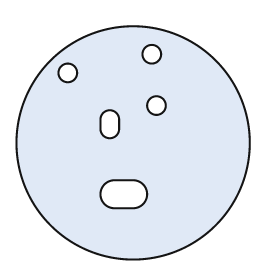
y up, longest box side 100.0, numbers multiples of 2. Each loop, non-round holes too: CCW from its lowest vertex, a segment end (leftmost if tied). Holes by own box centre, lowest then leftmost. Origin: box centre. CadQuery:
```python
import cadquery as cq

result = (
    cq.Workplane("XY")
    .moveTo(0.0, 0.0)
    .circle(50.0)
    .moveTo(-8.0, -28.0)
    .lineTo(0.0, -28.0)
    .threePointArc((6.0, -22.0), (0.0, -16.0))
    .lineTo(-8.0, -16.0)
    .threePointArc((-14.0, -22.0), (-8.0, -28.0))
    .close()
    .moveTo(-14.0, 6.0)
    .threePointArc((-10.0, 2.0), (-6.0, 6.0))
    .lineTo(-6.0, 10.0)
    .threePointArc((-10.0, 14.0), (-14.0, 10.0))
    .close()
    .moveTo(10.0, 16.0)
    .circle(4.0)
    .moveTo(-28.0, 30.0)
    .circle(4.0)
    .moveTo(8.0, 38.0)
    .circle(4.0)
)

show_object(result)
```